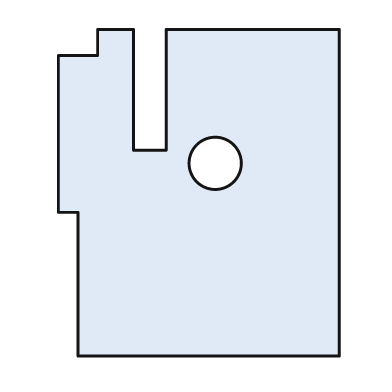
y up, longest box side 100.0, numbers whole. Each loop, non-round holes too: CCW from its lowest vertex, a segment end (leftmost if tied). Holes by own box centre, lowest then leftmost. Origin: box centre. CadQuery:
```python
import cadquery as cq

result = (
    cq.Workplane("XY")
    .moveTo(-37.0, -50.0)
    .lineTo(43.0, -50.0)
    .lineTo(43.0, 50.0)
    .lineTo(-10.0, 50.0)
    .lineTo(-10.0, 13.0)
    .lineTo(-20.0, 13.0)
    .lineTo(-20.0, 50.0)
    .lineTo(-31.0, 50.0)
    .lineTo(-31.0, 42.0)
    .lineTo(-43.0, 42.0)
    .lineTo(-43.0, -6.0)
    .lineTo(-37.0, -6.0)
    .close()
    .moveTo(5.0, 9.0)
    .circle(8.0)
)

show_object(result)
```